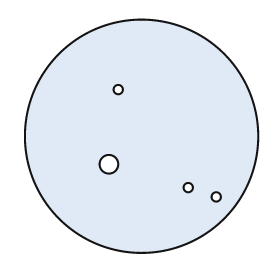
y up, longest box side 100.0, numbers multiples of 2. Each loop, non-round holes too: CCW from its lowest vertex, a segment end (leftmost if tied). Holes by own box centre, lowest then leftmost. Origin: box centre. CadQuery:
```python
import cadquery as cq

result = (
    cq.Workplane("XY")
    .moveTo(0.0, 0.0)
    .circle(50.0)
    .moveTo(32.0, -26.0)
    .circle(2.0)
    .moveTo(20.0, -22.0)
    .circle(2.0)
    .moveTo(-14.0, -12.0)
    .circle(4.0)
    .moveTo(-10.0, 20.0)
    .circle(2.0)
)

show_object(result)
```